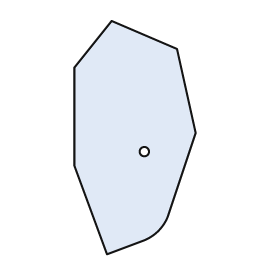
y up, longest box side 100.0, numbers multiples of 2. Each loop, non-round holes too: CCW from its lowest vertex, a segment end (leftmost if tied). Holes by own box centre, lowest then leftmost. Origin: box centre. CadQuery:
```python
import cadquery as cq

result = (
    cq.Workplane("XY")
    .moveTo(-12.0, -50.0)
    .lineTo(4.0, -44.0)
    .threePointArc((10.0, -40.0), (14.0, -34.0))
    .lineTo(26.0, 2.0)
    .lineTo(18.0, 38.0)
    .lineTo(-10.0, 50.0)
    .lineTo(-26.0, 30.0)
    .lineTo(-26.0, -12.0)
    .close()
    .moveTo(4.0, -6.0)
    .circle(2.0)
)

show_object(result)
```